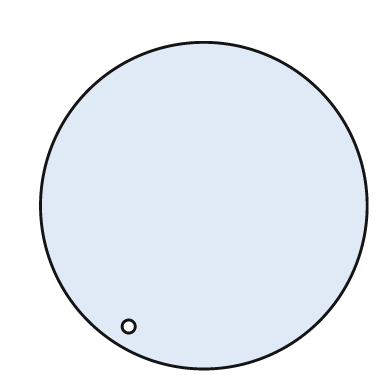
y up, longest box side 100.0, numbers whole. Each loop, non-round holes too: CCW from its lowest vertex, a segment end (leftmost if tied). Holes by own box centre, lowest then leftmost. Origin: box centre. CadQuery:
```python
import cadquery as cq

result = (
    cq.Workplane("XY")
    .moveTo(0.0, 0.0)
    .circle(50.0)
    .moveTo(-23.0, -37.0)
    .circle(2.0)
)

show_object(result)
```